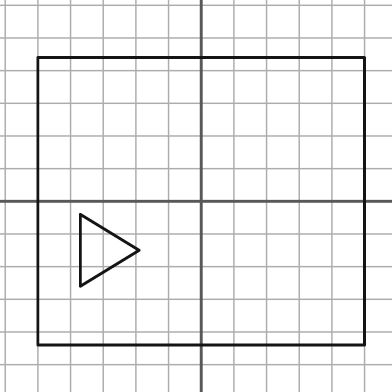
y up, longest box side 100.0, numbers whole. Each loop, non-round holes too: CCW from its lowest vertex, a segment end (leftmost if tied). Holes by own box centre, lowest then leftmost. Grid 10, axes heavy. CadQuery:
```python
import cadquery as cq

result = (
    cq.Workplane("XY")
    .moveTo(-50.0, -44.0)
    .lineTo(50.0, -44.0)
    .lineTo(50.0, 44.0)
    .lineTo(-50.0, 44.0)
    .close()
    .moveTo(-37.0, -26.0)
    .lineTo(-19.0, -15.0)
    .lineTo(-37.0, -4.0)
    .close()
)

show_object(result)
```